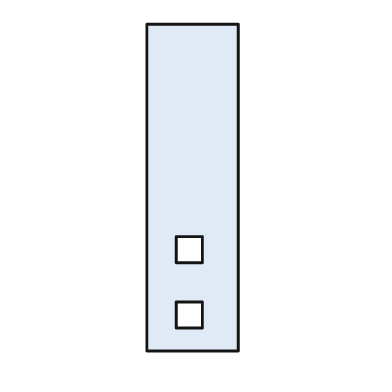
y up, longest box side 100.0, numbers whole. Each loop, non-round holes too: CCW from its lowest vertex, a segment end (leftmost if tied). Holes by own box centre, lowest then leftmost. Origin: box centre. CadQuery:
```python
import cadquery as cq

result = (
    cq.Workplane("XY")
    .moveTo(-14.0, -50.0)
    .lineTo(14.0, -50.0)
    .lineTo(14.0, 50.0)
    .lineTo(-14.0, 50.0)
    .close()
    .moveTo(-5.0, -43.0)
    .lineTo(3.0, -43.0)
    .lineTo(3.0, -35.0)
    .lineTo(-5.0, -35.0)
    .close()
    .moveTo(-5.0, -23.0)
    .lineTo(3.0, -23.0)
    .lineTo(3.0, -15.0)
    .lineTo(-5.0, -15.0)
    .close()
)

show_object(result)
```